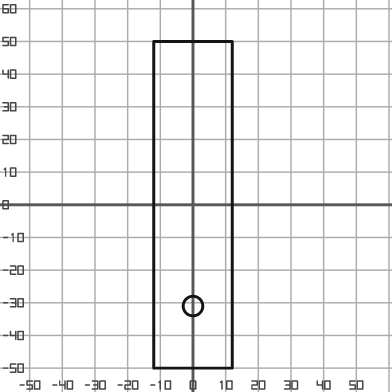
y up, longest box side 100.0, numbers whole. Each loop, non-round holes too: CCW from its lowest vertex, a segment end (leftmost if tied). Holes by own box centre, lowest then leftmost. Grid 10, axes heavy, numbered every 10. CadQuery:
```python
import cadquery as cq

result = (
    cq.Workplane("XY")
    .moveTo(-12.0, -50.0)
    .lineTo(12.0, -50.0)
    .lineTo(12.0, 50.0)
    .lineTo(-12.0, 50.0)
    .close()
    .moveTo(0.0, -31.0)
    .circle(3.0)
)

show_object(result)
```